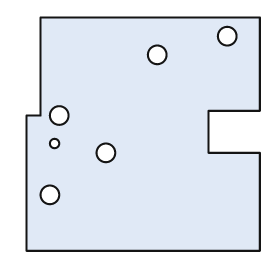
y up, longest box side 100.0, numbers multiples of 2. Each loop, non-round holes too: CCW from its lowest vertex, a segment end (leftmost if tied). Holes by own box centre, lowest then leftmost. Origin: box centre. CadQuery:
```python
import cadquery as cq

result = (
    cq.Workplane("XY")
    .moveTo(-50.0, -50.0)
    .lineTo(50.0, -50.0)
    .lineTo(50.0, -8.0)
    .lineTo(28.0, -8.0)
    .lineTo(28.0, 10.0)
    .lineTo(50.0, 10.0)
    .lineTo(50.0, 50.0)
    .lineTo(-44.0, 50.0)
    .lineTo(-44.0, 8.0)
    .lineTo(-50.0, 8.0)
    .close()
    .moveTo(-40.0, -26.0)
    .circle(4.0)
    .moveTo(-16.0, -8.0)
    .circle(4.0)
    .moveTo(-38.0, -4.0)
    .circle(2.0)
    .moveTo(-36.0, 8.0)
    .circle(4.0)
    .moveTo(6.0, 34.0)
    .circle(4.0)
    .moveTo(36.0, 42.0)
    .circle(4.0)
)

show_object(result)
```